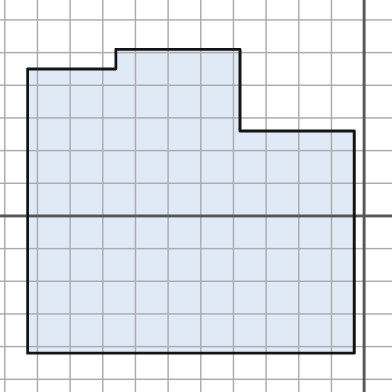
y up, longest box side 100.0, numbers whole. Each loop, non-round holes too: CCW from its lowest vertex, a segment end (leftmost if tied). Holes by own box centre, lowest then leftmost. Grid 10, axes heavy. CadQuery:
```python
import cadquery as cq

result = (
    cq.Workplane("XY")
    .moveTo(-103.0, -42.0)
    .lineTo(-3.0, -42.0)
    .lineTo(-3.0, 26.0)
    .lineTo(-38.0, 26.0)
    .lineTo(-38.0, 51.0)
    .lineTo(-76.0, 51.0)
    .lineTo(-76.0, 45.0)
    .lineTo(-103.0, 45.0)
    .close()
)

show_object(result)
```